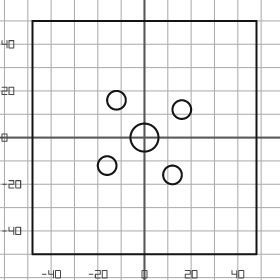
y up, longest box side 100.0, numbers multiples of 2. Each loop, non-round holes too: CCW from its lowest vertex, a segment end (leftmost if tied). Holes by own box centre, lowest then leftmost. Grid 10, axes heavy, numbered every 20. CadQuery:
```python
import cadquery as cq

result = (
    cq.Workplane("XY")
    .moveTo(-48.0, -50.0)
    .lineTo(48.0, -50.0)
    .lineTo(48.0, 50.0)
    .lineTo(-48.0, 50.0)
    .close()
    .moveTo(12.0, -16.0)
    .circle(4.0)
    .moveTo(-16.0, -12.0)
    .circle(4.0)
    .moveTo(0.0, 0.0)
    .circle(6.0)
    .moveTo(16.0, 12.0)
    .circle(4.0)
    .moveTo(-12.0, 16.0)
    .circle(4.0)
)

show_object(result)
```